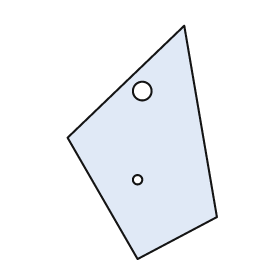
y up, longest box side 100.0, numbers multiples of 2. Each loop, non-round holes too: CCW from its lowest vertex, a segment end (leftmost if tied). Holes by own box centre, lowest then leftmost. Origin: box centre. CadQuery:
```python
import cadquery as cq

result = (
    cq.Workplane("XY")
    .moveTo(-2.0, -50.0)
    .lineTo(32.0, -32.0)
    .lineTo(18.0, 50.0)
    .lineTo(-32.0, 2.0)
    .close()
    .moveTo(-2.0, -16.0)
    .circle(2.0)
    .moveTo(0.0, 22.0)
    .circle(4.0)
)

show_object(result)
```